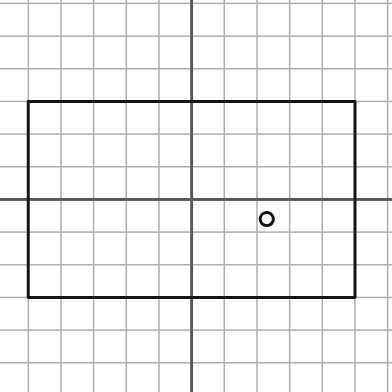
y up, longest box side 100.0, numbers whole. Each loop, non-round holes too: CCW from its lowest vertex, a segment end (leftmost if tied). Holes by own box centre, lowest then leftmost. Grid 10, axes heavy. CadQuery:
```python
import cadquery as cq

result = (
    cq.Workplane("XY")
    .moveTo(-50.0, -30.0)
    .lineTo(50.0, -30.0)
    .lineTo(50.0, 30.0)
    .lineTo(-50.0, 30.0)
    .close()
    .moveTo(23.0, -6.0)
    .circle(2.0)
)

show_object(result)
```